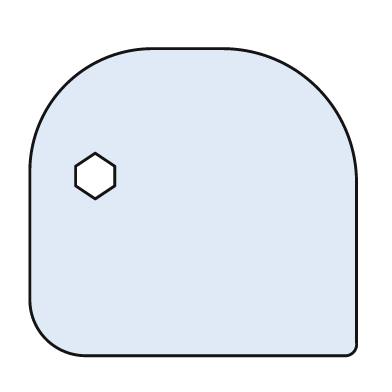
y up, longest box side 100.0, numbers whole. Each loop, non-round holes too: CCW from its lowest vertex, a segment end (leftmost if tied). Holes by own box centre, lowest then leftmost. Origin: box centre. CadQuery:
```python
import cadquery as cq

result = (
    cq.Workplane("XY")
    .moveTo(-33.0, -47.0)
    .lineTo(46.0, -47.0)
    .threePointArc((49.0, -46.0), (50.0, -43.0))
    .lineTo(50.0, 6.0)
    .threePointArc((38.0, 35.0), (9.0, 47.0))
    .lineTo(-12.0, 47.0)
    .threePointArc((-39.0, 36.0), (-50.0, 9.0))
    .lineTo(-50.0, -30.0)
    .threePointArc((-45.0, -42.0), (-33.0, -47.0))
    .close()
    .moveTo(-30.0, 1.0)
    .lineTo(-24.0, 5.0)
    .lineTo(-24.0, 11.0)
    .lineTo(-30.0, 15.0)
    .lineTo(-36.0, 11.0)
    .lineTo(-36.0, 5.0)
    .close()
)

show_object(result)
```